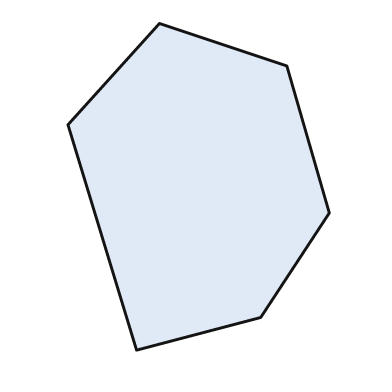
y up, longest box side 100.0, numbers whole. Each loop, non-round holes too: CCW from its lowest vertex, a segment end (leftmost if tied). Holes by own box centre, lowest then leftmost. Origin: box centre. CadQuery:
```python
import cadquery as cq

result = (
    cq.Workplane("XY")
    .moveTo(-19.0, -50.0)
    .lineTo(19.0, -40.0)
    .lineTo(40.0, -8.0)
    .lineTo(27.0, 37.0)
    .lineTo(-12.0, 50.0)
    .lineTo(-40.0, 19.0)
    .close()
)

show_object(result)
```